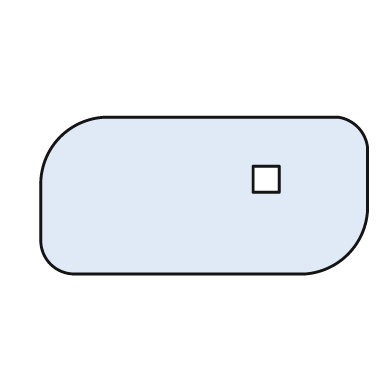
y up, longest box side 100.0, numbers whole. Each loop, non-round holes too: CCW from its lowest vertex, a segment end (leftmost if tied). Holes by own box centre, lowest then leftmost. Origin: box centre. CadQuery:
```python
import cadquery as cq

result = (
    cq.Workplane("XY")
    .moveTo(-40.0, -24.0)
    .lineTo(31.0, -24.0)
    .threePointArc((44.0, -18.0), (50.0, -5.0))
    .lineTo(50.0, 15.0)
    .threePointArc((47.0, 21.0), (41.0, 24.0))
    .lineTo(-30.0, 24.0)
    .threePointArc((-44.0, 18.0), (-50.0, 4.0))
    .lineTo(-50.0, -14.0)
    .threePointArc((-47.0, -21.0), (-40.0, -24.0))
    .close()
    .moveTo(15.0, 1.0)
    .lineTo(23.0, 1.0)
    .lineTo(23.0, 9.0)
    .lineTo(15.0, 9.0)
    .close()
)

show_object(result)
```